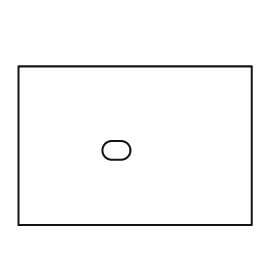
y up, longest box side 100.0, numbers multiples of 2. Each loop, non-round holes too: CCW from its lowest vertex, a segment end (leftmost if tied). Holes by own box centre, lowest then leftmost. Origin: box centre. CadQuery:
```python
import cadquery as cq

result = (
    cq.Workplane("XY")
    .moveTo(-50.0, -34.0)
    .lineTo(50.0, -34.0)
    .lineTo(50.0, 34.0)
    .lineTo(-50.0, 34.0)
    .close()
    .moveTo(-10.0, -6.0)
    .lineTo(-6.0, -6.0)
    .threePointArc((-2.0, -2.0), (-6.0, 2.0))
    .lineTo(-10.0, 2.0)
    .threePointArc((-14.0, -2.0), (-10.0, -6.0))
    .close()
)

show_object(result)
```